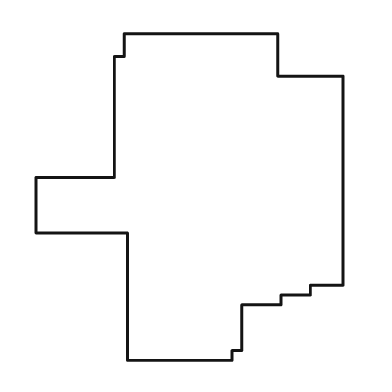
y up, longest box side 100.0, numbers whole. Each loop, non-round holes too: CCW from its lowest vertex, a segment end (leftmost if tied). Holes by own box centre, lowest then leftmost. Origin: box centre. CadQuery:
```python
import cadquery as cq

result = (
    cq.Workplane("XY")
    .moveTo(-19.0, -50.0)
    .lineTo(13.0, -50.0)
    .lineTo(13.0, -47.0)
    .lineTo(16.0, -47.0)
    .lineTo(16.0, -33.0)
    .lineTo(28.0, -33.0)
    .lineTo(28.0, -30.0)
    .lineTo(37.0, -30.0)
    .lineTo(37.0, -27.0)
    .lineTo(47.0, -27.0)
    .lineTo(47.0, 37.0)
    .lineTo(27.0, 37.0)
    .lineTo(27.0, 50.0)
    .lineTo(-20.0, 50.0)
    .lineTo(-20.0, 43.0)
    .lineTo(-23.0, 43.0)
    .lineTo(-23.0, 6.0)
    .lineTo(-47.0, 6.0)
    .lineTo(-47.0, -11.0)
    .lineTo(-19.0, -11.0)
    .close()
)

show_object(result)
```